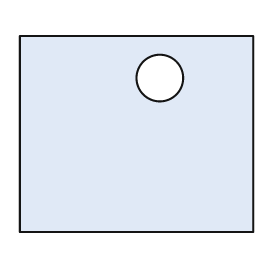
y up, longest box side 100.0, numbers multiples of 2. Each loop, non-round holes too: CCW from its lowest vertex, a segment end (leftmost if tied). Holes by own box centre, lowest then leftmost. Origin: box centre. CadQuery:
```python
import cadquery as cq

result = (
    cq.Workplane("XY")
    .moveTo(-50.0, -42.0)
    .lineTo(50.0, -42.0)
    .lineTo(50.0, 42.0)
    .lineTo(-50.0, 42.0)
    .close()
    .moveTo(10.0, 24.0)
    .circle(10.0)
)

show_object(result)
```